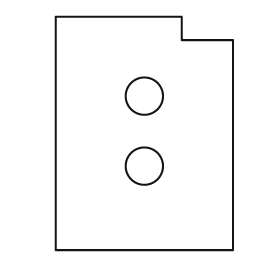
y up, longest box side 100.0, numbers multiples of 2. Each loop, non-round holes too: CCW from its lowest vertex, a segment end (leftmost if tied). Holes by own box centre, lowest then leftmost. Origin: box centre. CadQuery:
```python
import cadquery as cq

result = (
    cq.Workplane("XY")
    .moveTo(-38.0, -50.0)
    .lineTo(38.0, -50.0)
    .lineTo(38.0, 40.0)
    .lineTo(16.0, 40.0)
    .lineTo(16.0, 50.0)
    .lineTo(-38.0, 50.0)
    .close()
    .moveTo(0.0, -14.0)
    .circle(8.0)
    .moveTo(0.0, 16.0)
    .circle(8.0)
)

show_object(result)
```